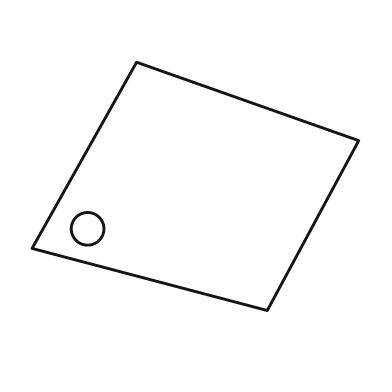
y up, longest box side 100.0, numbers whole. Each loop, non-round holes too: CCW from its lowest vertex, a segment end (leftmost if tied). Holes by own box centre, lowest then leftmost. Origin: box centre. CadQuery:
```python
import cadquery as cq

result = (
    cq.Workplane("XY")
    .moveTo(22.0, -38.0)
    .lineTo(50.0, 14.0)
    .lineTo(-18.0, 38.0)
    .lineTo(-50.0, -19.0)
    .close()
    .moveTo(-33.0, -13.0)
    .circle(5.0)
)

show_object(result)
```